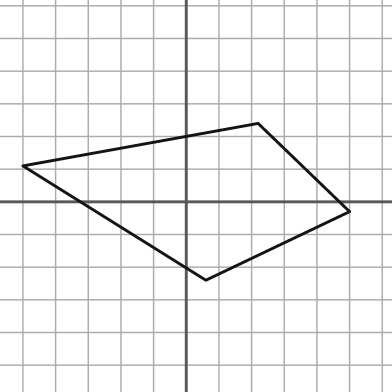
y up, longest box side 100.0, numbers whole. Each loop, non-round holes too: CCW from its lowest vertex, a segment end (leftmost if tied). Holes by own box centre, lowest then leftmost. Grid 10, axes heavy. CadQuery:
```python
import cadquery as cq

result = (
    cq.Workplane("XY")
    .moveTo(6.0, -24.0)
    .lineTo(50.0, -3.0)
    .lineTo(22.0, 24.0)
    .lineTo(-50.0, 11.0)
    .close()
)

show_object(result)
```